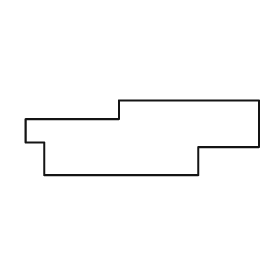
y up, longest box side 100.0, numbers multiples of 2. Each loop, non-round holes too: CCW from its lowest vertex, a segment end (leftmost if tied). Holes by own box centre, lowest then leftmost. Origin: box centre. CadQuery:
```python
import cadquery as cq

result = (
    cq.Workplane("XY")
    .moveTo(-42.0, -16.0)
    .lineTo(24.0, -16.0)
    .lineTo(24.0, -4.0)
    .lineTo(50.0, -4.0)
    .lineTo(50.0, 16.0)
    .lineTo(-10.0, 16.0)
    .lineTo(-10.0, 8.0)
    .lineTo(-50.0, 8.0)
    .lineTo(-50.0, -2.0)
    .lineTo(-42.0, -2.0)
    .close()
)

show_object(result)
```